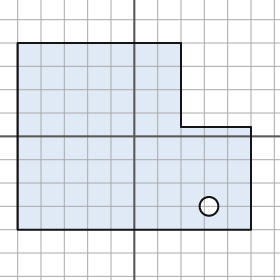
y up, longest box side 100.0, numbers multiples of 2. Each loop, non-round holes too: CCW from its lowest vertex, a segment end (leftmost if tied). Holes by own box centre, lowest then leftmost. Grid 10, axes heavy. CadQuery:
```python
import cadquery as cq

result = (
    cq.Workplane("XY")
    .moveTo(-50.0, -40.0)
    .lineTo(50.0, -40.0)
    .lineTo(50.0, 4.0)
    .lineTo(20.0, 4.0)
    .lineTo(20.0, 40.0)
    .lineTo(-50.0, 40.0)
    .close()
    .moveTo(32.0, -30.0)
    .circle(4.0)
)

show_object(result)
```